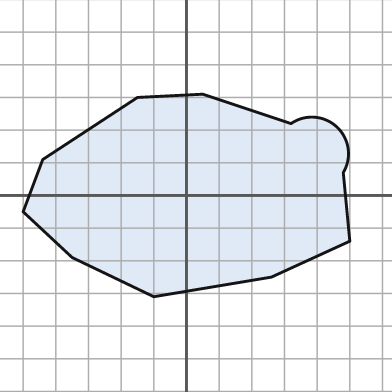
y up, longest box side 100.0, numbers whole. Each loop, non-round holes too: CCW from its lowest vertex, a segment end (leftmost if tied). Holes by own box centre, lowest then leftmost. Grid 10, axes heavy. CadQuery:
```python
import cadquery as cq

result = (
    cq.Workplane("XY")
    .moveTo(-10.0, -31.0)
    .lineTo(26.0, -25.0)
    .lineTo(50.0, -14.0)
    .lineTo(48.0, 7.0)
    .threePointArc((46.0, 21.0), (32.0, 22.0))
    .lineTo(5.0, 31.0)
    .lineTo(-15.0, 30.0)
    .lineTo(-44.0, 11.0)
    .lineTo(-50.0, -5.0)
    .lineTo(-35.0, -19.0)
    .close()
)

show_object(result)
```